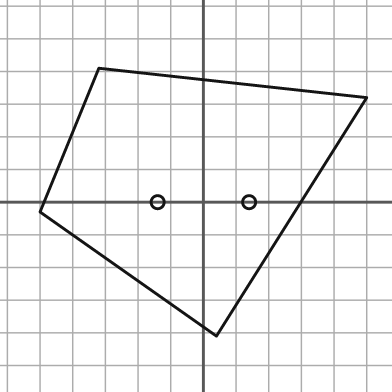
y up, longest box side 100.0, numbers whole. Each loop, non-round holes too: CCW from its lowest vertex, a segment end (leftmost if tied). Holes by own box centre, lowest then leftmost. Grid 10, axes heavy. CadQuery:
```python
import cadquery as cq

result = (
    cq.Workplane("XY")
    .moveTo(4.0, -41.0)
    .lineTo(50.0, 32.0)
    .lineTo(-32.0, 41.0)
    .lineTo(-50.0, -3.0)
    .close()
    .moveTo(-14.0, 0.0)
    .circle(2.0)
    .moveTo(14.0, 0.0)
    .circle(2.0)
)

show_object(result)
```